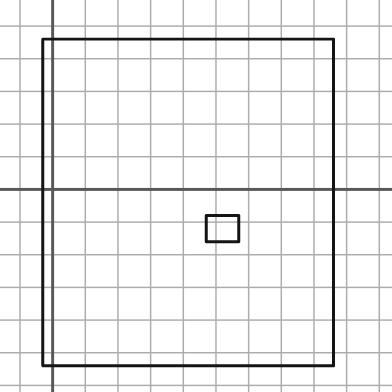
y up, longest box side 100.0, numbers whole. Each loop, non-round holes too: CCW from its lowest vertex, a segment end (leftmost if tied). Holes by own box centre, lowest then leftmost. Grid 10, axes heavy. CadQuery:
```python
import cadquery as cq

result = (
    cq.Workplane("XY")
    .moveTo(-3.0, -54.0)
    .lineTo(86.0, -54.0)
    .lineTo(86.0, 46.0)
    .lineTo(-3.0, 46.0)
    .close()
    .moveTo(47.0, -16.0)
    .lineTo(57.0, -16.0)
    .lineTo(57.0, -8.0)
    .lineTo(47.0, -8.0)
    .close()
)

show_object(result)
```